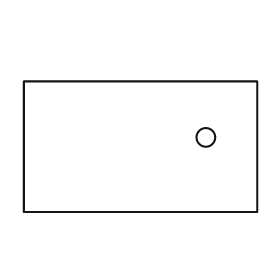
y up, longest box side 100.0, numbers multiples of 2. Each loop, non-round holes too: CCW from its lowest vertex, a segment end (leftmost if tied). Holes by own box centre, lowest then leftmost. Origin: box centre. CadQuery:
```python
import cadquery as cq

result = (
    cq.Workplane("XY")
    .moveTo(-50.0, -28.0)
    .lineTo(50.0, -28.0)
    .lineTo(50.0, 28.0)
    .lineTo(-50.0, 28.0)
    .close()
    .moveTo(28.0, 4.0)
    .circle(4.0)
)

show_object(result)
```